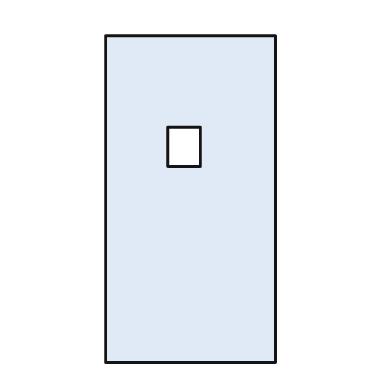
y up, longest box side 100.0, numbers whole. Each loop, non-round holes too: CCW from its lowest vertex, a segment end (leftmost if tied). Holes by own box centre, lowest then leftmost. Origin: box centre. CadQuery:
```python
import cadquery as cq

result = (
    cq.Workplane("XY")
    .moveTo(-26.0, -50.0)
    .lineTo(26.0, -50.0)
    .lineTo(26.0, 50.0)
    .lineTo(-26.0, 50.0)
    .close()
    .moveTo(-7.0, 10.0)
    .lineTo(3.0, 10.0)
    .lineTo(3.0, 22.0)
    .lineTo(-7.0, 22.0)
    .close()
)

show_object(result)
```